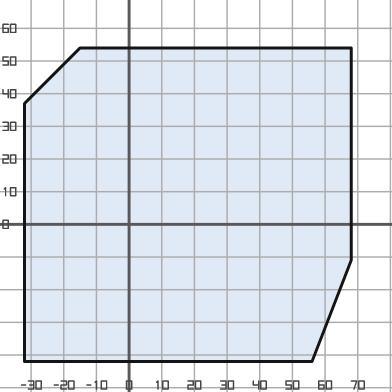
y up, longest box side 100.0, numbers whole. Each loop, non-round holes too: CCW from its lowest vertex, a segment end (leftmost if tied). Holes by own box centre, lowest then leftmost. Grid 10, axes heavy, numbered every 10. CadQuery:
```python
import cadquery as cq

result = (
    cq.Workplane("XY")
    .moveTo(-32.0, -42.0)
    .lineTo(56.0, -42.0)
    .lineTo(68.0, -11.0)
    .lineTo(68.0, 54.0)
    .lineTo(-15.0, 54.0)
    .lineTo(-32.0, 37.0)
    .close()
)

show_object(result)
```